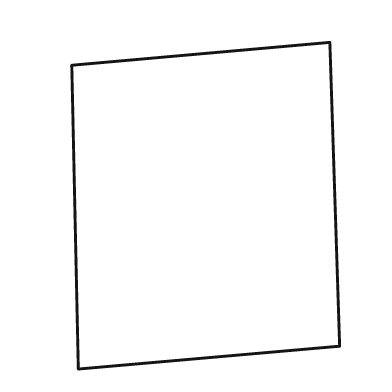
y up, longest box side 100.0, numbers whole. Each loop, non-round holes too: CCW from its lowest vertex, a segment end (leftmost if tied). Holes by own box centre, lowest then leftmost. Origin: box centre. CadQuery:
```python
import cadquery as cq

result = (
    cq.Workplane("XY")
    .moveTo(-39.0, -50.0)
    .lineTo(41.0, -43.0)
    .lineTo(38.0, 50.0)
    .lineTo(-41.0, 43.0)
    .close()
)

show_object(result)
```